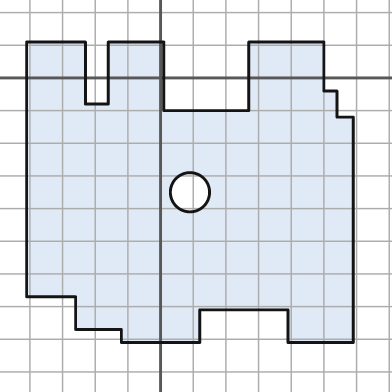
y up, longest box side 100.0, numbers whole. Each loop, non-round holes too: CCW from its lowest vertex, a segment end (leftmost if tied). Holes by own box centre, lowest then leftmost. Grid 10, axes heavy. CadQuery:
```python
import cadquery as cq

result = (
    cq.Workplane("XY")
    .moveTo(-12.0, -81.0)
    .lineTo(12.0, -81.0)
    .lineTo(12.0, -71.0)
    .lineTo(39.0, -71.0)
    .lineTo(39.0, -81.0)
    .lineTo(59.0, -81.0)
    .lineTo(59.0, -12.0)
    .lineTo(54.0, -12.0)
    .lineTo(54.0, -4.0)
    .lineTo(50.0, -4.0)
    .lineTo(50.0, 11.0)
    .lineTo(27.0, 11.0)
    .lineTo(27.0, -10.0)
    .lineTo(1.0, -10.0)
    .lineTo(1.0, 11.0)
    .lineTo(-16.0, 11.0)
    .lineTo(-16.0, -8.0)
    .lineTo(-23.0, -8.0)
    .lineTo(-23.0, 11.0)
    .lineTo(-41.0, 11.0)
    .lineTo(-41.0, -67.0)
    .lineTo(-26.0, -67.0)
    .lineTo(-26.0, -77.0)
    .lineTo(-12.0, -77.0)
    .close()
    .moveTo(9.0, -35.0)
    .circle(6.0)
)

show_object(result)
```